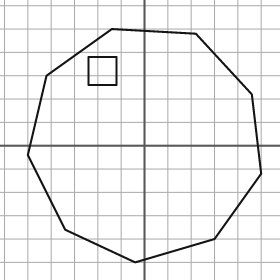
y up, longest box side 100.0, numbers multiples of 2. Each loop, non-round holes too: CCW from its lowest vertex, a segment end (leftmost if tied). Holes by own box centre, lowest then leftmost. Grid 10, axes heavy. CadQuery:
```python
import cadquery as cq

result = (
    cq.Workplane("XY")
    .moveTo(-4.0, -50.0)
    .lineTo(30.0, -40.0)
    .lineTo(50.0, -12.0)
    .lineTo(46.0, 22.0)
    .lineTo(22.0, 48.0)
    .lineTo(-14.0, 50.0)
    .lineTo(-42.0, 30.0)
    .lineTo(-50.0, -4.0)
    .lineTo(-34.0, -36.0)
    .close()
    .moveTo(-24.0, 26.0)
    .lineTo(-12.0, 26.0)
    .lineTo(-12.0, 38.0)
    .lineTo(-24.0, 38.0)
    .close()
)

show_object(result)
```